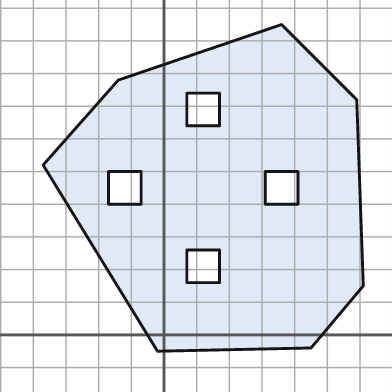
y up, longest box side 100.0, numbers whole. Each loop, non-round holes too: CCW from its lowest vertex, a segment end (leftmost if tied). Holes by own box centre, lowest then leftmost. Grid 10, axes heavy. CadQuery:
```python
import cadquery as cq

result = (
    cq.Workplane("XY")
    .moveTo(-2.0, -5.0)
    .lineTo(45.0, -4.0)
    .lineTo(61.0, 15.0)
    .lineTo(59.0, 72.0)
    .lineTo(36.0, 95.0)
    .lineTo(-14.0, 78.0)
    .lineTo(-37.0, 52.0)
    .close()
    .moveTo(7.0, 16.0)
    .lineTo(17.0, 16.0)
    .lineTo(17.0, 26.0)
    .lineTo(7.0, 26.0)
    .close()
    .moveTo(-17.0, 40.0)
    .lineTo(-7.0, 40.0)
    .lineTo(-7.0, 50.0)
    .lineTo(-17.0, 50.0)
    .close()
    .moveTo(31.0, 40.0)
    .lineTo(41.0, 40.0)
    .lineTo(41.0, 50.0)
    .lineTo(31.0, 50.0)
    .close()
    .moveTo(7.0, 64.0)
    .lineTo(17.0, 64.0)
    .lineTo(17.0, 74.0)
    .lineTo(7.0, 74.0)
    .close()
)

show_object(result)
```